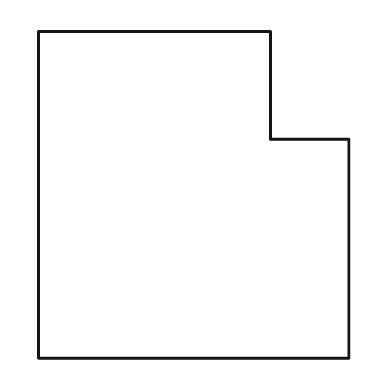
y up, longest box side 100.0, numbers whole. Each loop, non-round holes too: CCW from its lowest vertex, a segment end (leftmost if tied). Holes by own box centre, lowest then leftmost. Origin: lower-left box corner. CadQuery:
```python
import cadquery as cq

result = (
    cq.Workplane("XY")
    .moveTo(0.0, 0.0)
    .lineTo(95.0, 0.0)
    .lineTo(95.0, 67.0)
    .lineTo(71.0, 67.0)
    .lineTo(71.0, 100.0)
    .lineTo(0.0, 100.0)
    .close()
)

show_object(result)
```